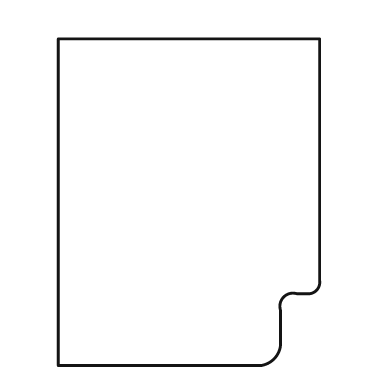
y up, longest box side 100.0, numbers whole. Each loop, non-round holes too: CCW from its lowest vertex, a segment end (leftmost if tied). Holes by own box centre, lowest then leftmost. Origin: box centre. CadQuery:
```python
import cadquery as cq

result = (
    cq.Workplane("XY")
    .moveTo(-40.0, -50.0)
    .lineTo(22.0, -50.0)
    .threePointArc((26.0, -48.0), (28.0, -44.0))
    .lineTo(28.0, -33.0)
    .threePointArc((29.0, -29.0), (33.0, -28.0))
    .lineTo(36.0, -28.0)
    .threePointArc((39.0, -27.0), (40.0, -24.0))
    .lineTo(40.0, 50.0)
    .lineTo(-40.0, 50.0)
    .close()
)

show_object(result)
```